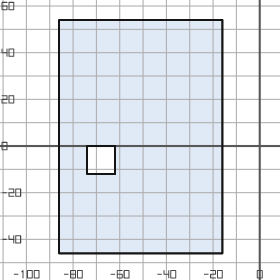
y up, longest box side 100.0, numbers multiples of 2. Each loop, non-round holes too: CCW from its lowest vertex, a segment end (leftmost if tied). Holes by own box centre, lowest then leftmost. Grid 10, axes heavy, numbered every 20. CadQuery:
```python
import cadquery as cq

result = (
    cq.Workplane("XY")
    .moveTo(-86.0, -46.0)
    .lineTo(-16.0, -46.0)
    .lineTo(-16.0, 54.0)
    .lineTo(-86.0, 54.0)
    .close()
    .moveTo(-74.0, -12.0)
    .lineTo(-62.0, -12.0)
    .lineTo(-62.0, 0.0)
    .lineTo(-74.0, 0.0)
    .close()
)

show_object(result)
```